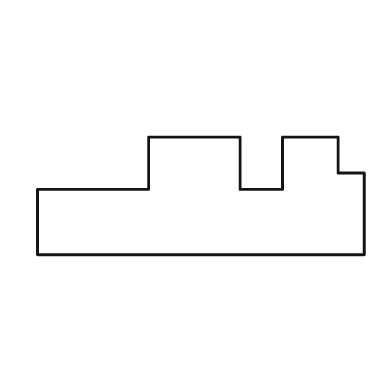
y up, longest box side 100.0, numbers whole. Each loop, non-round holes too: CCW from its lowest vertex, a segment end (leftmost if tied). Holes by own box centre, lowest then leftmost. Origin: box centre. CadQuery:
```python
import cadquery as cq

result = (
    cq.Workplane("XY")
    .moveTo(-50.0, -18.0)
    .lineTo(50.0, -18.0)
    .lineTo(50.0, 7.0)
    .lineTo(42.0, 7.0)
    .lineTo(42.0, 18.0)
    .lineTo(25.0, 18.0)
    .lineTo(25.0, 2.0)
    .lineTo(12.0, 2.0)
    .lineTo(12.0, 18.0)
    .lineTo(-16.0, 18.0)
    .lineTo(-16.0, 2.0)
    .lineTo(-50.0, 2.0)
    .close()
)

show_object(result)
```